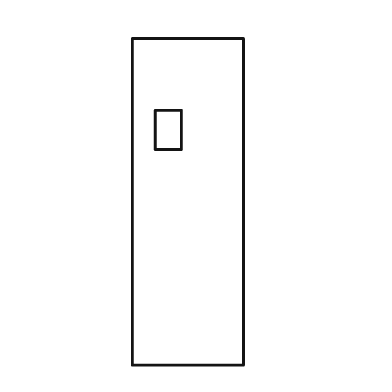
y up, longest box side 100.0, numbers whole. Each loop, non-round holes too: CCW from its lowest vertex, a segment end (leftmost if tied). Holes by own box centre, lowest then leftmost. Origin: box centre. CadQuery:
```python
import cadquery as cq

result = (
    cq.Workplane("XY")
    .moveTo(-17.0, -50.0)
    .lineTo(17.0, -50.0)
    .lineTo(17.0, 50.0)
    .lineTo(-17.0, 50.0)
    .close()
    .moveTo(-10.0, 16.0)
    .lineTo(-2.0, 16.0)
    .lineTo(-2.0, 28.0)
    .lineTo(-10.0, 28.0)
    .close()
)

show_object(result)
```